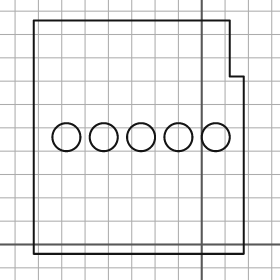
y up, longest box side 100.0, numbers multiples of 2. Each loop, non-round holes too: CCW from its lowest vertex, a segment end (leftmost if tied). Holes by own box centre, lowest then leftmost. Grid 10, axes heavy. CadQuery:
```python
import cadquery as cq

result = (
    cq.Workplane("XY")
    .moveTo(-72.0, -4.0)
    .lineTo(18.0, -4.0)
    .lineTo(18.0, 72.0)
    .lineTo(12.0, 72.0)
    .lineTo(12.0, 96.0)
    .lineTo(-72.0, 96.0)
    .close()
    .moveTo(-58.0, 46.0)
    .circle(6.0)
    .moveTo(-42.0, 46.0)
    .circle(6.0)
    .moveTo(-26.0, 46.0)
    .circle(6.0)
    .moveTo(-10.0, 46.0)
    .circle(6.0)
    .moveTo(6.0, 46.0)
    .circle(6.0)
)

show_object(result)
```